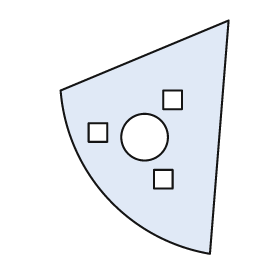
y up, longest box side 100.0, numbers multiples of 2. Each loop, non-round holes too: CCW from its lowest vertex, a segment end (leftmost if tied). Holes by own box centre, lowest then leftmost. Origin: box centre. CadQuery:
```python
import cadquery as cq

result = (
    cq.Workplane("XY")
    .moveTo(28.0, -50.0)
    .lineTo(36.0, 50.0)
    .lineTo(-36.0, 20.0)
    .threePointArc((-16.0, -26.0), (28.0, -50.0))
    .close()
    .moveTo(4.0, -22.0)
    .lineTo(12.0, -22.0)
    .lineTo(12.0, -14.0)
    .lineTo(4.0, -14.0)
    .close()
    .moveTo(0.0, 0.0)
    .circle(10.0)
    .moveTo(-24.0, -2.0)
    .lineTo(-16.0, -2.0)
    .lineTo(-16.0, 6.0)
    .lineTo(-24.0, 6.0)
    .close()
    .moveTo(8.0, 12.0)
    .lineTo(16.0, 12.0)
    .lineTo(16.0, 20.0)
    .lineTo(8.0, 20.0)
    .close()
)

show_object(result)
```